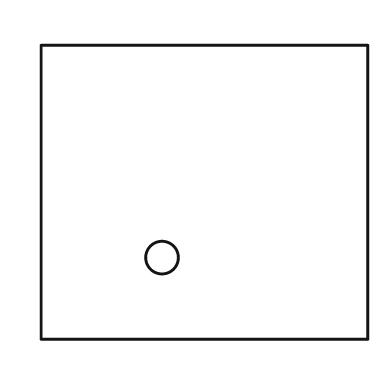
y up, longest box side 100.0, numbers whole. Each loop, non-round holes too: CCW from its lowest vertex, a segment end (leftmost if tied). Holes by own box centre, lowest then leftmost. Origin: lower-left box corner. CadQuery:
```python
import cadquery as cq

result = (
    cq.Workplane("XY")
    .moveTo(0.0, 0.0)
    .lineTo(100.0, 0.0)
    .lineTo(100.0, 90.0)
    .lineTo(0.0, 90.0)
    .close()
    .moveTo(37.0, 25.0)
    .circle(5.0)
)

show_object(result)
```